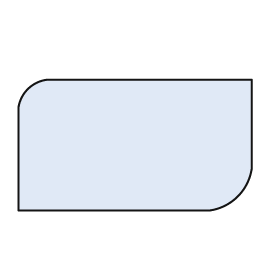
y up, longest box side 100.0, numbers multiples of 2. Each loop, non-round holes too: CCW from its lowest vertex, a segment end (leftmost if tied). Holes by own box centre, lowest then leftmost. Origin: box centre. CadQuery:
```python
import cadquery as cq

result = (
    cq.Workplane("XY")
    .moveTo(-50.0, -28.0)
    .lineTo(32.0, -28.0)
    .threePointArc((44.0, -22.0), (50.0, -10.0))
    .lineTo(50.0, 28.0)
    .lineTo(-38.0, 28.0)
    .threePointArc((-46.0, 24.0), (-50.0, 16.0))
    .close()
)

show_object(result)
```